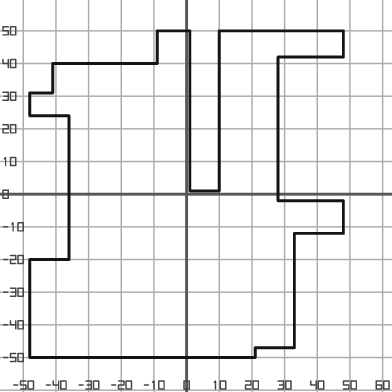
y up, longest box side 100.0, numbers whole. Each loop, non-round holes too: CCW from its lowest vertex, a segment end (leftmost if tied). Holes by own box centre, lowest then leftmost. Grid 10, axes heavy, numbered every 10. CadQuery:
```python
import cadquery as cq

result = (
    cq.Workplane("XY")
    .moveTo(-48.0, -50.0)
    .lineTo(21.0, -50.0)
    .lineTo(21.0, -47.0)
    .lineTo(33.0, -47.0)
    .lineTo(33.0, -12.0)
    .lineTo(48.0, -12.0)
    .lineTo(48.0, -2.0)
    .lineTo(28.0, -2.0)
    .lineTo(28.0, 42.0)
    .lineTo(48.0, 42.0)
    .lineTo(48.0, 50.0)
    .lineTo(10.0, 50.0)
    .lineTo(10.0, 1.0)
    .lineTo(1.0, 1.0)
    .lineTo(1.0, 50.0)
    .lineTo(-9.0, 50.0)
    .lineTo(-9.0, 40.0)
    .lineTo(-41.0, 40.0)
    .lineTo(-41.0, 31.0)
    .lineTo(-48.0, 31.0)
    .lineTo(-48.0, 24.0)
    .lineTo(-36.0, 24.0)
    .lineTo(-36.0, -20.0)
    .lineTo(-48.0, -20.0)
    .close()
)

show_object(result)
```